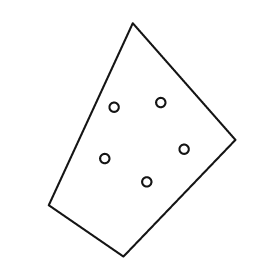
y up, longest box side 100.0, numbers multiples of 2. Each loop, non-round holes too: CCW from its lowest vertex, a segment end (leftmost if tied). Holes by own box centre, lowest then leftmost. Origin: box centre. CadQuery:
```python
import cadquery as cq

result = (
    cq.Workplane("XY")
    .moveTo(-8.0, -50.0)
    .lineTo(40.0, 0.0)
    .lineTo(-4.0, 50.0)
    .lineTo(-40.0, -28.0)
    .close()
    .moveTo(2.0, -18.0)
    .circle(2.0)
    .moveTo(-16.0, -8.0)
    .circle(2.0)
    .moveTo(18.0, -4.0)
    .circle(2.0)
    .moveTo(-12.0, 14.0)
    .circle(2.0)
    .moveTo(8.0, 16.0)
    .circle(2.0)
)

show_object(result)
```